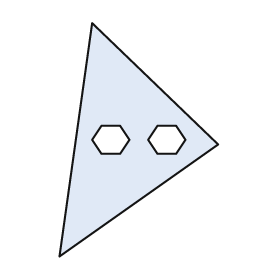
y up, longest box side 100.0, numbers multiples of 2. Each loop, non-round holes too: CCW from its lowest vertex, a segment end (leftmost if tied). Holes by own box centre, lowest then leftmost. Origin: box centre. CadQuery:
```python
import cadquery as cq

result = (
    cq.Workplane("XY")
    .moveTo(-34.0, -50.0)
    .lineTo(34.0, -2.0)
    .lineTo(-20.0, 50.0)
    .close()
    .moveTo(-16.0, -6.0)
    .lineTo(-8.0, -6.0)
    .lineTo(-4.0, 0.0)
    .lineTo(-8.0, 6.0)
    .lineTo(-16.0, 6.0)
    .lineTo(-20.0, 0.0)
    .close()
    .moveTo(8.0, -6.0)
    .lineTo(16.0, -6.0)
    .lineTo(20.0, 0.0)
    .lineTo(16.0, 6.0)
    .lineTo(8.0, 6.0)
    .lineTo(4.0, 0.0)
    .close()
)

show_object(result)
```